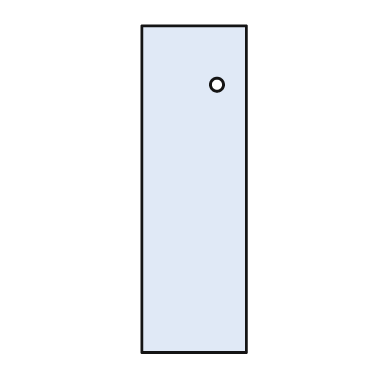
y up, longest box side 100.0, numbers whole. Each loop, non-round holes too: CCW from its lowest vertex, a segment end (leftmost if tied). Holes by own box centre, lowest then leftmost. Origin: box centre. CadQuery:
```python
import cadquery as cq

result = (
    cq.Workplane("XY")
    .moveTo(-16.0, -50.0)
    .lineTo(16.0, -50.0)
    .lineTo(16.0, 50.0)
    .lineTo(-16.0, 50.0)
    .close()
    .moveTo(7.0, 32.0)
    .circle(2.0)
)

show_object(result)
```